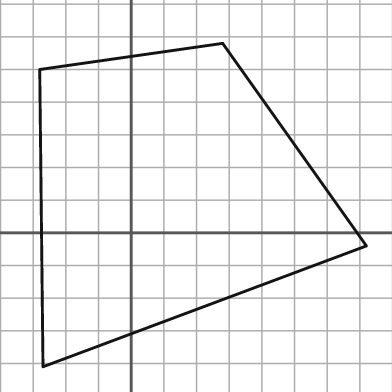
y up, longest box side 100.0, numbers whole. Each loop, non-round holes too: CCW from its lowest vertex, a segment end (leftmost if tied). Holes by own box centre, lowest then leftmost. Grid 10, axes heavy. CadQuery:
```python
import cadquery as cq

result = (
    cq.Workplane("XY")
    .moveTo(-27.0, -41.0)
    .lineTo(72.0, -4.0)
    .lineTo(28.0, 58.0)
    .lineTo(-28.0, 50.0)
    .close()
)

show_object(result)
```